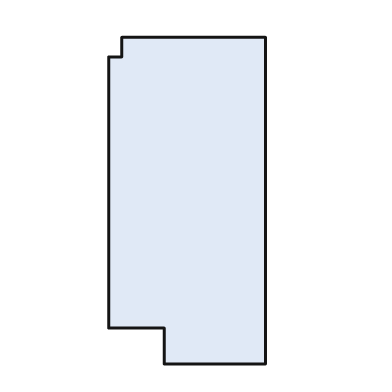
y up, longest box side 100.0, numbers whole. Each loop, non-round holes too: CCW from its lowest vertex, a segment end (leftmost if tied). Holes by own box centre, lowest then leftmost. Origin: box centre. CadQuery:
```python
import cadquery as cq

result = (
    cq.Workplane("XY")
    .moveTo(-7.0, -50.0)
    .lineTo(24.0, -50.0)
    .lineTo(24.0, 50.0)
    .lineTo(-20.0, 50.0)
    .lineTo(-20.0, 44.0)
    .lineTo(-24.0, 44.0)
    .lineTo(-24.0, -39.0)
    .lineTo(-7.0, -39.0)
    .close()
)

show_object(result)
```